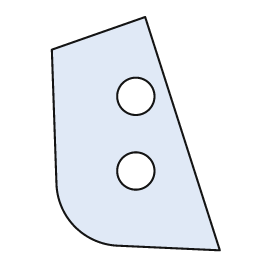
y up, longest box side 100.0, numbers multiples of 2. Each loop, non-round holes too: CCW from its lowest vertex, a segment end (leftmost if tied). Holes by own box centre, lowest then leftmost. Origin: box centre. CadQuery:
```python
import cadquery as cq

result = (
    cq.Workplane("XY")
    .moveTo(36.0, -50.0)
    .lineTo(4.0, 50.0)
    .lineTo(-36.0, 36.0)
    .lineTo(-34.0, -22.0)
    .threePointArc((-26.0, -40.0), (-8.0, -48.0))
    .close()
    .moveTo(0.0, -16.0)
    .circle(8.0)
    .moveTo(0.0, 16.0)
    .circle(8.0)
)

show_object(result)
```